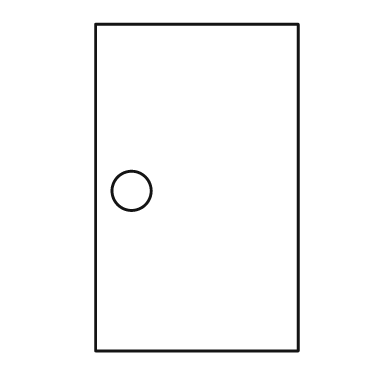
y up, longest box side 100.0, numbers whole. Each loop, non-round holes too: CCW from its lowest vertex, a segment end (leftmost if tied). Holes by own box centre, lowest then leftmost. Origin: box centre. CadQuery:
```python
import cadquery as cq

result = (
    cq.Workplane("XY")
    .moveTo(-31.0, -50.0)
    .lineTo(31.0, -50.0)
    .lineTo(31.0, 50.0)
    .lineTo(-31.0, 50.0)
    .close()
    .moveTo(-20.0, -1.0)
    .circle(6.0)
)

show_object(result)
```